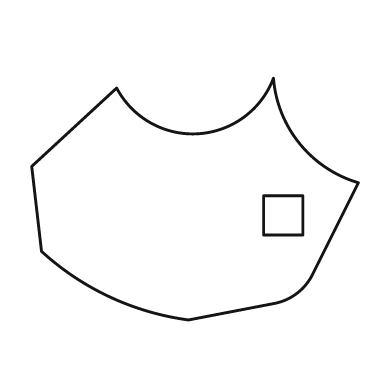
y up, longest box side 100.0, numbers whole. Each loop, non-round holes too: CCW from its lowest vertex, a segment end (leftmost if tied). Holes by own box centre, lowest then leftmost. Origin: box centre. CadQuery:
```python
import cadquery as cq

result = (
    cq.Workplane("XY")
    .moveTo(-2.0, -37.0)
    .lineTo(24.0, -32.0)
    .threePointArc((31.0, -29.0), (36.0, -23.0))
    .lineTo(50.0, 5.0)
    .threePointArc((32.0, 17.0), (24.0, 37.0))
    .threePointArc((1.0, 20.0), (-24.0, 34.0))
    .lineTo(-50.0, 10.0)
    .lineTo(-47.0, -16.0)
    .threePointArc((-26.0, -30.0), (-2.0, -37.0))
    .close()
    .moveTo(21.0, -11.0)
    .lineTo(33.0, -11.0)
    .lineTo(33.0, 1.0)
    .lineTo(21.0, 1.0)
    .close()
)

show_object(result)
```